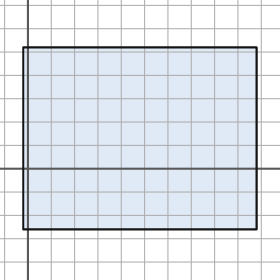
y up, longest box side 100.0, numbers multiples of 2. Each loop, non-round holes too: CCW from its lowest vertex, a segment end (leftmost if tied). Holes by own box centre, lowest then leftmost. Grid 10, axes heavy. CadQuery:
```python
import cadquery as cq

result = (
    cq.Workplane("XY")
    .moveTo(-2.0, -26.0)
    .lineTo(98.0, -26.0)
    .lineTo(98.0, 52.0)
    .lineTo(-2.0, 52.0)
    .close()
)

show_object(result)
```